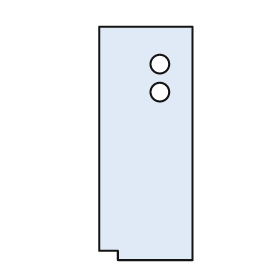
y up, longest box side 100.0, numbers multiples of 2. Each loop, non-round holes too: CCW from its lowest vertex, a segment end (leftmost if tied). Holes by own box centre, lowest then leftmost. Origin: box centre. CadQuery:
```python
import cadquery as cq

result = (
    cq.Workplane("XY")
    .moveTo(-12.0, -50.0)
    .lineTo(20.0, -50.0)
    .lineTo(20.0, 50.0)
    .lineTo(-20.0, 50.0)
    .lineTo(-20.0, -46.0)
    .lineTo(-12.0, -46.0)
    .close()
    .moveTo(6.0, 22.0)
    .circle(4.0)
    .moveTo(6.0, 34.0)
    .circle(4.0)
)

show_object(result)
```